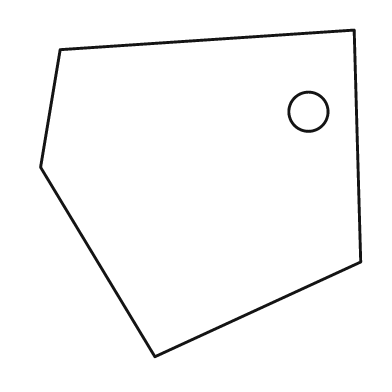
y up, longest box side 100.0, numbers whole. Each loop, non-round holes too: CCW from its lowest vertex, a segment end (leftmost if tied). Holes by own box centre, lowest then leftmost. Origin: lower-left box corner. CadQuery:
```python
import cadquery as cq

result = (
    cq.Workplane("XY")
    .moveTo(35.0, 0.0)
    .lineTo(98.0, 29.0)
    .lineTo(96.0, 100.0)
    .lineTo(6.0, 94.0)
    .lineTo(0.0, 58.0)
    .close()
    .moveTo(82.0, 75.0)
    .circle(6.0)
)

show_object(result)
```